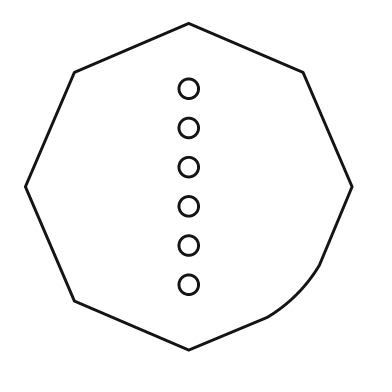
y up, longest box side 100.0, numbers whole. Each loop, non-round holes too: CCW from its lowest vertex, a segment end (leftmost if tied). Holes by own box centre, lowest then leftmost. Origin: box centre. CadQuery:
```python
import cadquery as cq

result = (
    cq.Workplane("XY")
    .moveTo(0.0, -50.0)
    .lineTo(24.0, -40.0)
    .threePointArc((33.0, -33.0), (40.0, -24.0))
    .lineTo(50.0, 0.0)
    .lineTo(35.0, 35.0)
    .lineTo(0.0, 50.0)
    .lineTo(-35.0, 35.0)
    .lineTo(-50.0, 0.0)
    .lineTo(-35.0, -35.0)
    .close()
    .moveTo(0.0, -30.0)
    .circle(3.0)
    .moveTo(0.0, -18.0)
    .circle(3.0)
    .moveTo(0.0, -6.0)
    .circle(3.0)
    .moveTo(0.0, 6.0)
    .circle(3.0)
    .moveTo(0.0, 18.0)
    .circle(3.0)
    .moveTo(0.0, 30.0)
    .circle(3.0)
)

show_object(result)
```